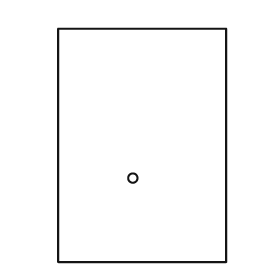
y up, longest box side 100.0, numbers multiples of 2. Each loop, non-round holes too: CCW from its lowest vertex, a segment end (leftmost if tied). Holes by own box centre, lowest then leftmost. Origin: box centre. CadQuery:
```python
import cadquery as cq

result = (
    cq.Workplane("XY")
    .moveTo(-36.0, -50.0)
    .lineTo(36.0, -50.0)
    .lineTo(36.0, 50.0)
    .lineTo(-36.0, 50.0)
    .close()
    .moveTo(-4.0, -14.0)
    .circle(2.0)
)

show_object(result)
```